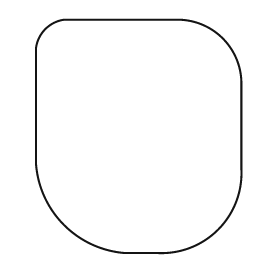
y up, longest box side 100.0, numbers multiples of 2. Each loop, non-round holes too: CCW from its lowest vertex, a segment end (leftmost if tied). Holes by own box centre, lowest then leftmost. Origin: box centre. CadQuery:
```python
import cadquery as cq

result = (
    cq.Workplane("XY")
    .moveTo(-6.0, -50.0)
    .lineTo(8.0, -50.0)
    .threePointArc((34.0, -40.0), (44.0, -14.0))
    .lineTo(44.0, 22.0)
    .threePointArc((36.0, 42.0), (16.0, 50.0))
    .lineTo(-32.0, 50.0)
    .threePointArc((-40.0, 46.0), (-44.0, 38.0))
    .lineTo(-44.0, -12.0)
    .threePointArc((-32.0, -38.0), (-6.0, -50.0))
    .close()
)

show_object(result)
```